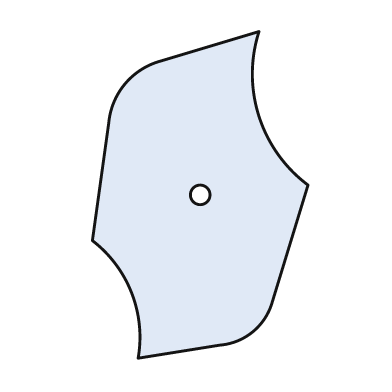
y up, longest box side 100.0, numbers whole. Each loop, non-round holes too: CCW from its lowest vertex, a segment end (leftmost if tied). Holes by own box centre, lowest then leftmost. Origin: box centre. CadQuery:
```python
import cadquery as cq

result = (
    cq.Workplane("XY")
    .moveTo(-19.0, -50.0)
    .lineTo(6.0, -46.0)
    .threePointArc((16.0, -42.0), (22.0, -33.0))
    .lineTo(33.0, 3.0)
    .threePointArc((18.0, 24.0), (18.0, 50.0))
    .lineTo(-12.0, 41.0)
    .threePointArc((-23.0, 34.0), (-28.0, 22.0))
    .lineTo(-33.0, -14.0)
    .threePointArc((-21.0, -30.0), (-19.0, -50.0))
    .close()
    .moveTo(0.0, 0.0)
    .circle(3.0)
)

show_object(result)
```